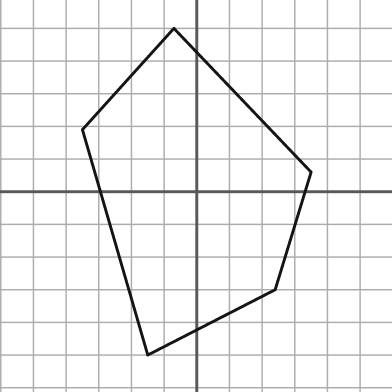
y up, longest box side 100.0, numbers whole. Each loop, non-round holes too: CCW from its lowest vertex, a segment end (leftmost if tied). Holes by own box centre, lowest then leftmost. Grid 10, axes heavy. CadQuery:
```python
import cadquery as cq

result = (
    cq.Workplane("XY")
    .moveTo(-15.0, -50.0)
    .lineTo(24.0, -30.0)
    .lineTo(35.0, 6.0)
    .lineTo(-7.0, 50.0)
    .lineTo(-35.0, 19.0)
    .close()
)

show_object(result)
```